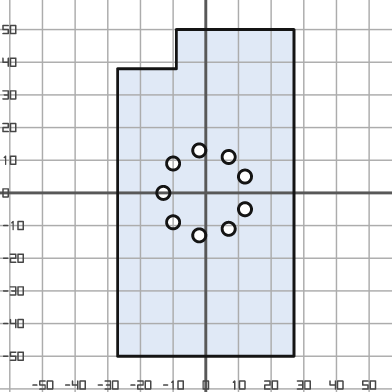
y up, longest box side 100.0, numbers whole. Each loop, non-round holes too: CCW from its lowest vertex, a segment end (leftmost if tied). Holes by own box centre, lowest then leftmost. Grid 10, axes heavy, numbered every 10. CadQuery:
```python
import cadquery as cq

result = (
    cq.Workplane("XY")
    .moveTo(-27.0, -50.0)
    .lineTo(27.0, -50.0)
    .lineTo(27.0, 50.0)
    .lineTo(-9.0, 50.0)
    .lineTo(-9.0, 38.0)
    .lineTo(-27.0, 38.0)
    .close()
    .moveTo(-2.0, -13.0)
    .circle(2.0)
    .moveTo(7.0, -11.0)
    .circle(2.0)
    .moveTo(-10.0, -9.0)
    .circle(2.0)
    .moveTo(12.0, -5.0)
    .circle(2.0)
    .moveTo(-13.0, 0.0)
    .circle(2.0)
    .moveTo(12.0, 5.0)
    .circle(2.0)
    .moveTo(-10.0, 9.0)
    .circle(2.0)
    .moveTo(7.0, 11.0)
    .circle(2.0)
    .moveTo(-2.0, 13.0)
    .circle(2.0)
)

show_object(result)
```